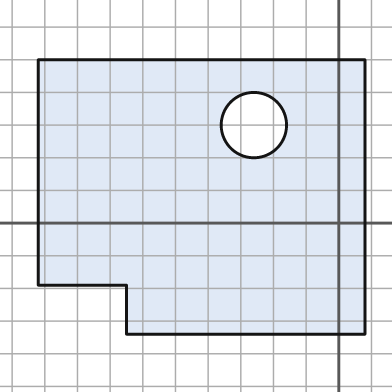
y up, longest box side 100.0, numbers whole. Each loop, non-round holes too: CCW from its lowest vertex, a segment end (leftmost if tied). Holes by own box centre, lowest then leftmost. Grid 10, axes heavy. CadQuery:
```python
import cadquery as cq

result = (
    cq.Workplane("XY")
    .moveTo(-65.0, -34.0)
    .lineTo(8.0, -34.0)
    .lineTo(8.0, 50.0)
    .lineTo(-92.0, 50.0)
    .lineTo(-92.0, -19.0)
    .lineTo(-65.0, -19.0)
    .close()
    .moveTo(-26.0, 30.0)
    .circle(10.0)
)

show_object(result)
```